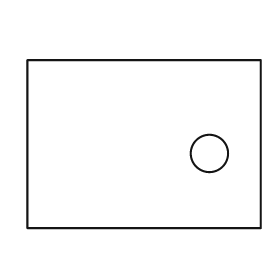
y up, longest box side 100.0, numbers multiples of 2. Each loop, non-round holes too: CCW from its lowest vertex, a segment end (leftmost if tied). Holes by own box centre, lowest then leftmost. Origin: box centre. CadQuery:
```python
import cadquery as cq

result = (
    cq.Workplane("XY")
    .moveTo(-50.0, -36.0)
    .lineTo(50.0, -36.0)
    .lineTo(50.0, 36.0)
    .lineTo(-50.0, 36.0)
    .close()
    .moveTo(28.0, -4.0)
    .circle(8.0)
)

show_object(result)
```